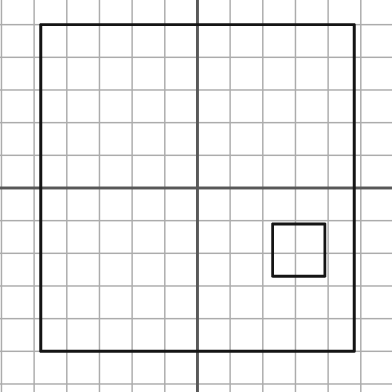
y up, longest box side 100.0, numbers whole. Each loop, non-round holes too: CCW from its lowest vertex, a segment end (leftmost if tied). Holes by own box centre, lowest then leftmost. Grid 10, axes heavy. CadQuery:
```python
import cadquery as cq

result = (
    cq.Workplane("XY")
    .moveTo(-48.0, -50.0)
    .lineTo(48.0, -50.0)
    .lineTo(48.0, 50.0)
    .lineTo(-48.0, 50.0)
    .close()
    .moveTo(23.0, -27.0)
    .lineTo(39.0, -27.0)
    .lineTo(39.0, -11.0)
    .lineTo(23.0, -11.0)
    .close()
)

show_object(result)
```